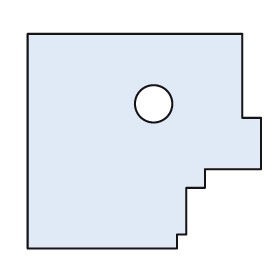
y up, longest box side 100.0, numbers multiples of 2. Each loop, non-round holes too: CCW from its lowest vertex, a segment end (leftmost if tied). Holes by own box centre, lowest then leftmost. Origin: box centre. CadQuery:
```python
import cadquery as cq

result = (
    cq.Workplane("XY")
    .moveTo(-50.0, -46.0)
    .lineTo(14.0, -46.0)
    .lineTo(14.0, -40.0)
    .lineTo(18.0, -40.0)
    .lineTo(18.0, -20.0)
    .lineTo(26.0, -20.0)
    .lineTo(26.0, -12.0)
    .lineTo(50.0, -12.0)
    .lineTo(50.0, 10.0)
    .lineTo(42.0, 10.0)
    .lineTo(42.0, 46.0)
    .lineTo(-50.0, 46.0)
    .close()
    .moveTo(4.0, 16.0)
    .circle(8.0)
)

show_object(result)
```